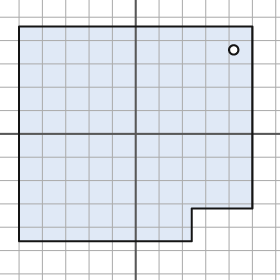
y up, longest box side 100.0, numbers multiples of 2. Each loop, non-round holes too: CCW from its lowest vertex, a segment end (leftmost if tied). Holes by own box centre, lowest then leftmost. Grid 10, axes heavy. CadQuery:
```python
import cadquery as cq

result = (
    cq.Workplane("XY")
    .moveTo(-50.0, -46.0)
    .lineTo(24.0, -46.0)
    .lineTo(24.0, -32.0)
    .lineTo(50.0, -32.0)
    .lineTo(50.0, 46.0)
    .lineTo(-50.0, 46.0)
    .close()
    .moveTo(42.0, 36.0)
    .circle(2.0)
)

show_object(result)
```